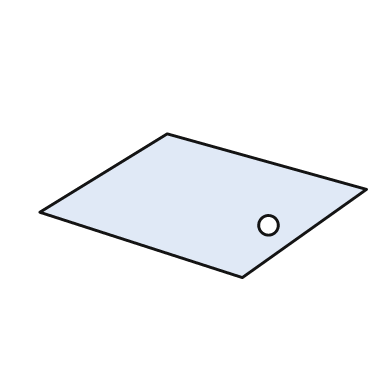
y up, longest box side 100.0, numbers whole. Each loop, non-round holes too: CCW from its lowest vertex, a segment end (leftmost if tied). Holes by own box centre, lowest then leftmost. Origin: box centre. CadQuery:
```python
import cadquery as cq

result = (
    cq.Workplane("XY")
    .moveTo(12.0, -22.0)
    .lineTo(50.0, 5.0)
    .lineTo(-11.0, 22.0)
    .lineTo(-50.0, -2.0)
    .close()
    .moveTo(20.0, -6.0)
    .circle(3.0)
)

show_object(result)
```